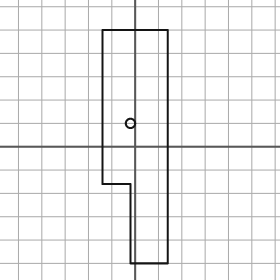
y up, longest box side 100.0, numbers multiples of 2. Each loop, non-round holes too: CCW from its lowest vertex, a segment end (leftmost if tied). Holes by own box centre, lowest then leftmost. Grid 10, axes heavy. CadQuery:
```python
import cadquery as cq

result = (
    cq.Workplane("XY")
    .moveTo(-2.0, -50.0)
    .lineTo(14.0, -50.0)
    .lineTo(14.0, 50.0)
    .lineTo(-14.0, 50.0)
    .lineTo(-14.0, -16.0)
    .lineTo(-2.0, -16.0)
    .close()
    .moveTo(-2.0, 10.0)
    .circle(2.0)
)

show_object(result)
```